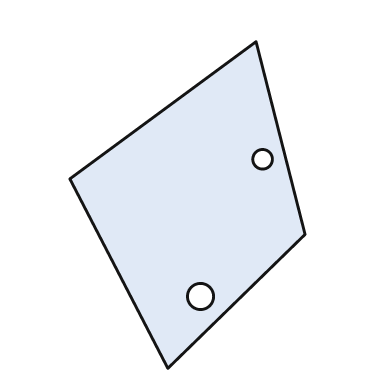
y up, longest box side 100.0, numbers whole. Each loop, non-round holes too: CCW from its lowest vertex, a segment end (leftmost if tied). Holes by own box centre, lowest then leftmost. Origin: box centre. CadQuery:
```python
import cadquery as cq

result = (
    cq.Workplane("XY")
    .moveTo(-6.0, -50.0)
    .lineTo(36.0, -9.0)
    .lineTo(21.0, 50.0)
    .lineTo(-36.0, 8.0)
    .close()
    .moveTo(4.0, -28.0)
    .circle(4.0)
    .moveTo(23.0, 14.0)
    .circle(3.0)
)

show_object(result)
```